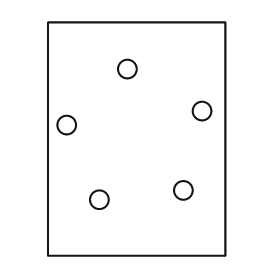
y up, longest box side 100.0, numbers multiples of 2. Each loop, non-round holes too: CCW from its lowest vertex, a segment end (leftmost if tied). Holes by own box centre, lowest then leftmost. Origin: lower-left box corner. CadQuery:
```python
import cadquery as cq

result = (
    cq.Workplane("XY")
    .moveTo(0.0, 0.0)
    .lineTo(76.0, 0.0)
    .lineTo(76.0, 100.0)
    .lineTo(0.0, 100.0)
    .close()
    .moveTo(22.0, 24.0)
    .circle(4.0)
    .moveTo(58.0, 28.0)
    .circle(4.0)
    .moveTo(8.0, 56.0)
    .circle(4.0)
    .moveTo(66.0, 62.0)
    .circle(4.0)
    .moveTo(34.0, 80.0)
    .circle(4.0)
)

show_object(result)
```